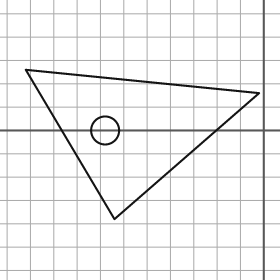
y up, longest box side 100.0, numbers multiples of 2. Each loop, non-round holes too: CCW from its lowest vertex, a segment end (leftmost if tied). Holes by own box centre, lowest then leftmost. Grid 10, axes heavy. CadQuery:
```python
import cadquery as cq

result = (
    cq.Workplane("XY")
    .moveTo(-64.0, -38.0)
    .lineTo(-2.0, 16.0)
    .lineTo(-102.0, 26.0)
    .close()
    .moveTo(-68.0, 0.0)
    .circle(6.0)
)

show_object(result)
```